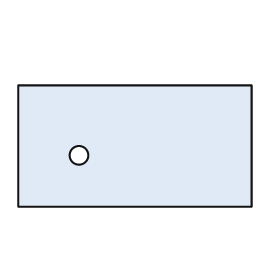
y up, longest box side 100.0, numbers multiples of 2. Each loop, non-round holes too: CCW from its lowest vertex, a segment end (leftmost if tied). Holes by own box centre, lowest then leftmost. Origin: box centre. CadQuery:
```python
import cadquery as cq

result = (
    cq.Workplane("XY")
    .moveTo(-50.0, -26.0)
    .lineTo(50.0, -26.0)
    .lineTo(50.0, 26.0)
    .lineTo(-50.0, 26.0)
    .close()
    .moveTo(-24.0, -4.0)
    .circle(4.0)
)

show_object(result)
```